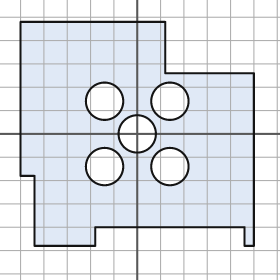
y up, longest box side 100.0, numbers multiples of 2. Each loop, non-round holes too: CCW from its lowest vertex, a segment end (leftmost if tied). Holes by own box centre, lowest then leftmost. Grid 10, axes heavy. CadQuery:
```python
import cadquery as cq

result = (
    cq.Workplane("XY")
    .moveTo(-44.0, -48.0)
    .lineTo(-18.0, -48.0)
    .lineTo(-18.0, -40.0)
    .lineTo(46.0, -40.0)
    .lineTo(46.0, -48.0)
    .lineTo(50.0, -48.0)
    .lineTo(50.0, 26.0)
    .lineTo(12.0, 26.0)
    .lineTo(12.0, 48.0)
    .lineTo(-50.0, 48.0)
    .lineTo(-50.0, -18.0)
    .lineTo(-44.0, -18.0)
    .close()
    .moveTo(-14.0, -14.0)
    .circle(8.0)
    .moveTo(14.0, -14.0)
    .circle(8.0)
    .moveTo(0.0, 0.0)
    .circle(8.0)
    .moveTo(-14.0, 14.0)
    .circle(8.0)
    .moveTo(14.0, 14.0)
    .circle(8.0)
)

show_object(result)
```